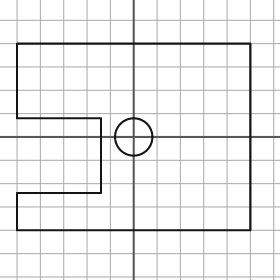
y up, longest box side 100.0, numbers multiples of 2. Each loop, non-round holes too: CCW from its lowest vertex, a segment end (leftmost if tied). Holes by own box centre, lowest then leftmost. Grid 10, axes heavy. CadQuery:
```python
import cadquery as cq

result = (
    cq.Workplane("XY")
    .moveTo(-50.0, -40.0)
    .lineTo(50.0, -40.0)
    .lineTo(50.0, 40.0)
    .lineTo(-50.0, 40.0)
    .lineTo(-50.0, 8.0)
    .lineTo(-14.0, 8.0)
    .lineTo(-14.0, -24.0)
    .lineTo(-50.0, -24.0)
    .close()
    .moveTo(0.0, 0.0)
    .circle(8.0)
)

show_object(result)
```